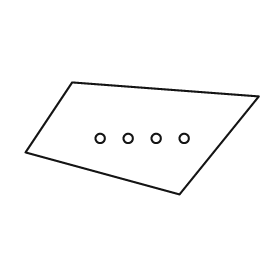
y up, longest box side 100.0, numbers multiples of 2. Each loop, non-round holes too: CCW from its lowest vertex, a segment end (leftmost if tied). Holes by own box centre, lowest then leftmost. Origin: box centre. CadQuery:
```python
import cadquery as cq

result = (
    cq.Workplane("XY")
    .moveTo(16.0, -24.0)
    .lineTo(50.0, 18.0)
    .lineTo(-30.0, 24.0)
    .lineTo(-50.0, -6.0)
    .close()
    .moveTo(-18.0, 0.0)
    .circle(2.0)
    .moveTo(-6.0, 0.0)
    .circle(2.0)
    .moveTo(6.0, 0.0)
    .circle(2.0)
    .moveTo(18.0, 0.0)
    .circle(2.0)
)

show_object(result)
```